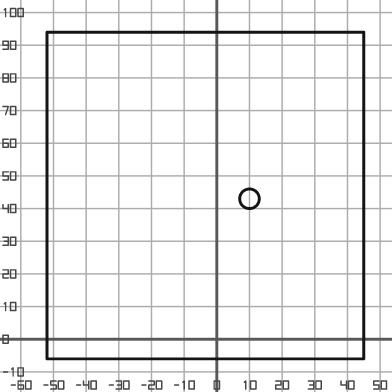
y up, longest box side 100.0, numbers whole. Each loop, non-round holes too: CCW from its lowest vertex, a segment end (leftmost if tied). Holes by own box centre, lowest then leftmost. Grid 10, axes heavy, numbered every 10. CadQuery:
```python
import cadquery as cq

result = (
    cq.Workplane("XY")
    .moveTo(-52.0, -6.0)
    .lineTo(45.0, -6.0)
    .lineTo(45.0, 94.0)
    .lineTo(-52.0, 94.0)
    .close()
    .moveTo(10.0, 43.0)
    .circle(3.0)
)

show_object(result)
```